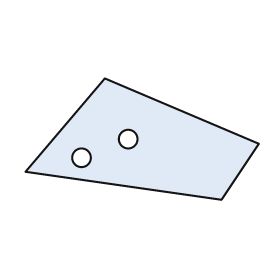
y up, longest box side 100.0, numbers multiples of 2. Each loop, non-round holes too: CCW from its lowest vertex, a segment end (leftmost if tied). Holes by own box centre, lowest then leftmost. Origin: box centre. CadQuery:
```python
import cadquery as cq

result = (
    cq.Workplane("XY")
    .moveTo(34.0, -26.0)
    .lineTo(50.0, -2.0)
    .lineTo(-16.0, 26.0)
    .lineTo(-50.0, -14.0)
    .close()
    .moveTo(-26.0, -8.0)
    .circle(4.0)
    .moveTo(-6.0, 0.0)
    .circle(4.0)
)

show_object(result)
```